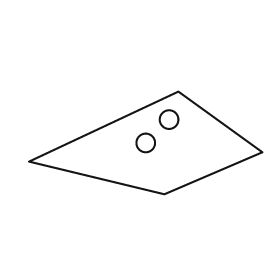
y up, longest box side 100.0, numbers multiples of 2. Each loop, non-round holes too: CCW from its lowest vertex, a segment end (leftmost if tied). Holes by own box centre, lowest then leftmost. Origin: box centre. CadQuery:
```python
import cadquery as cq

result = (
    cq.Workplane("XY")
    .moveTo(8.0, -22.0)
    .lineTo(50.0, -4.0)
    .lineTo(14.0, 22.0)
    .lineTo(-50.0, -8.0)
    .close()
    .moveTo(0.0, 0.0)
    .circle(4.0)
    .moveTo(10.0, 10.0)
    .circle(4.0)
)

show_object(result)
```